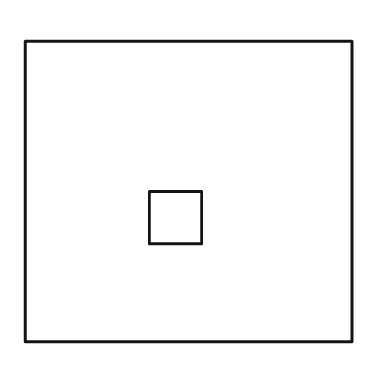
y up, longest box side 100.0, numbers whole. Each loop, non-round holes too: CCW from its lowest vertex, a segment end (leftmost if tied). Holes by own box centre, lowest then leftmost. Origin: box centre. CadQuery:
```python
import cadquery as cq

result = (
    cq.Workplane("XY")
    .moveTo(-50.0, -46.0)
    .lineTo(50.0, -46.0)
    .lineTo(50.0, 46.0)
    .lineTo(-50.0, 46.0)
    .close()
    .moveTo(-12.0, -16.0)
    .lineTo(4.0, -16.0)
    .lineTo(4.0, 0.0)
    .lineTo(-12.0, 0.0)
    .close()
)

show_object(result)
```